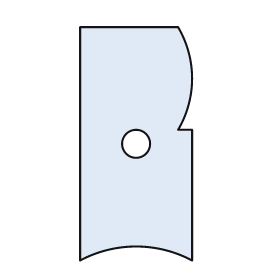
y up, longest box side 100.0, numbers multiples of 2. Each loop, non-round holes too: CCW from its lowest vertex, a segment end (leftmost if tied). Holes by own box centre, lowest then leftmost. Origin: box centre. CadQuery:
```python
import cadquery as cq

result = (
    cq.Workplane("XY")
    .moveTo(-24.0, -50.0)
    .threePointArc((0.0, -44.0), (24.0, -50.0))
    .lineTo(24.0, 6.0)
    .lineTo(18.0, 6.0)
    .threePointArc((24.0, 28.0), (18.0, 50.0))
    .lineTo(-24.0, 50.0)
    .close()
    .moveTo(0.0, 0.0)
    .circle(6.0)
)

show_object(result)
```